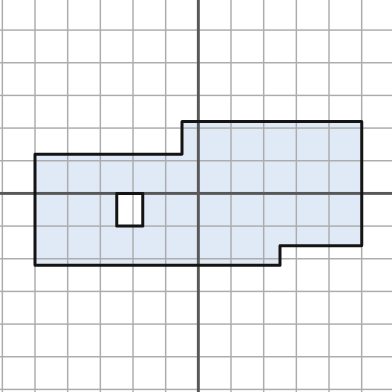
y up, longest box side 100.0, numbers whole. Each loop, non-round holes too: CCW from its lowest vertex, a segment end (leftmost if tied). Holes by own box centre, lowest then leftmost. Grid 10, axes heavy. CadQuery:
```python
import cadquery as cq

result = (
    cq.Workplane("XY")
    .moveTo(-50.0, -22.0)
    .lineTo(25.0, -22.0)
    .lineTo(25.0, -16.0)
    .lineTo(50.0, -16.0)
    .lineTo(50.0, 22.0)
    .lineTo(-5.0, 22.0)
    .lineTo(-5.0, 12.0)
    .lineTo(-50.0, 12.0)
    .close()
    .moveTo(-25.0, -10.0)
    .lineTo(-17.0, -10.0)
    .lineTo(-17.0, 0.0)
    .lineTo(-25.0, 0.0)
    .close()
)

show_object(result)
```